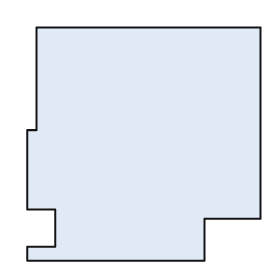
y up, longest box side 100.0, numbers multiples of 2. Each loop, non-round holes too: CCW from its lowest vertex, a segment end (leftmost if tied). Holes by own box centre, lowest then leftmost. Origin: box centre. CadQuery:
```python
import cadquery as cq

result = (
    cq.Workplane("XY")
    .moveTo(-50.0, -50.0)
    .lineTo(26.0, -50.0)
    .lineTo(26.0, -32.0)
    .lineTo(50.0, -32.0)
    .lineTo(50.0, 50.0)
    .lineTo(-46.0, 50.0)
    .lineTo(-46.0, 6.0)
    .lineTo(-50.0, 6.0)
    .lineTo(-50.0, -28.0)
    .lineTo(-38.0, -28.0)
    .lineTo(-38.0, -44.0)
    .lineTo(-50.0, -44.0)
    .close()
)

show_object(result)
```